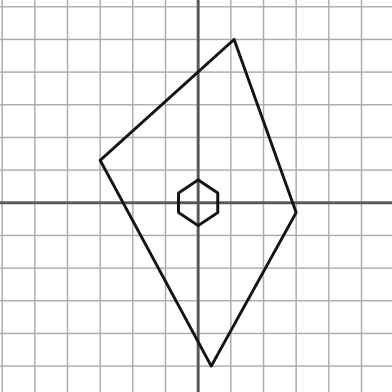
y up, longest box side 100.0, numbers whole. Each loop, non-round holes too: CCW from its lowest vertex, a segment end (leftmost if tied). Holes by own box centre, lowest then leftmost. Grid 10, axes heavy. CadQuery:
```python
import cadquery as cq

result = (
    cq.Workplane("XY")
    .moveTo(4.0, -50.0)
    .lineTo(30.0, -3.0)
    .lineTo(11.0, 50.0)
    .lineTo(-30.0, 13.0)
    .close()
    .moveTo(0.0, -7.0)
    .lineTo(6.0, -3.0)
    .lineTo(6.0, 3.0)
    .lineTo(0.0, 7.0)
    .lineTo(-6.0, 3.0)
    .lineTo(-6.0, -3.0)
    .close()
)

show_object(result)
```